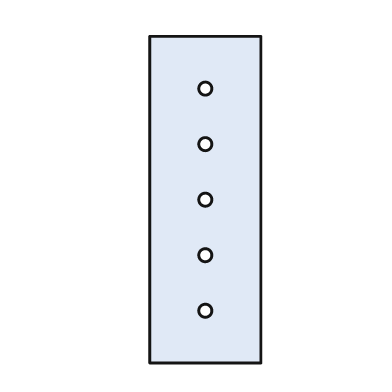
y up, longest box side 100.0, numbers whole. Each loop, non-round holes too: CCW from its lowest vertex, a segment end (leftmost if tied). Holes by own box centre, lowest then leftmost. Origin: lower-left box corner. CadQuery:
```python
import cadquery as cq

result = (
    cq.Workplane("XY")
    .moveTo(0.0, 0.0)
    .lineTo(34.0, 0.0)
    .lineTo(34.0, 100.0)
    .lineTo(0.0, 100.0)
    .close()
    .moveTo(17.0, 16.0)
    .circle(2.0)
    .moveTo(17.0, 33.0)
    .circle(2.0)
    .moveTo(17.0, 50.0)
    .circle(2.0)
    .moveTo(17.0, 67.0)
    .circle(2.0)
    .moveTo(17.0, 84.0)
    .circle(2.0)
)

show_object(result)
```